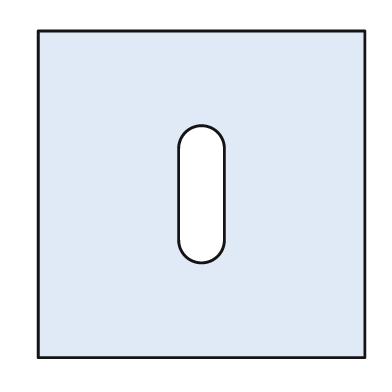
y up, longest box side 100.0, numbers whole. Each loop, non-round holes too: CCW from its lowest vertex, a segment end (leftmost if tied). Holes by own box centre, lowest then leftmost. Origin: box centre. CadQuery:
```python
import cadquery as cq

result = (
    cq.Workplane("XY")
    .moveTo(-50.0, -50.0)
    .lineTo(50.0, -50.0)
    .lineTo(50.0, 50.0)
    .lineTo(-50.0, 50.0)
    .close()
    .moveTo(-7.0, -14.0)
    .threePointArc((0.0, -21.0), (7.0, -14.0))
    .lineTo(7.0, 14.0)
    .threePointArc((0.0, 21.0), (-7.0, 14.0))
    .close()
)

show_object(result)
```